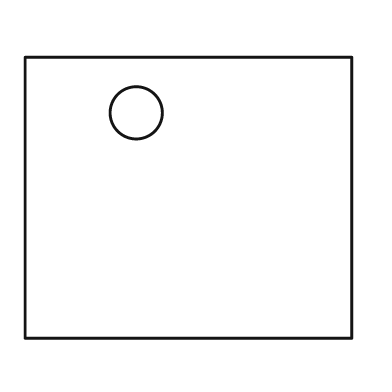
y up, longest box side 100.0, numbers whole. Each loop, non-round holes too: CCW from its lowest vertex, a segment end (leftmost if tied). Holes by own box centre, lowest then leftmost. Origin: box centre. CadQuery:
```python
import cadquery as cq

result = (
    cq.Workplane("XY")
    .moveTo(-50.0, -43.0)
    .lineTo(50.0, -43.0)
    .lineTo(50.0, 43.0)
    .lineTo(-50.0, 43.0)
    .close()
    .moveTo(-16.0, 26.0)
    .circle(8.0)
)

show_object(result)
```